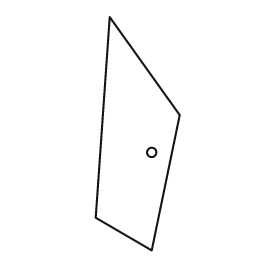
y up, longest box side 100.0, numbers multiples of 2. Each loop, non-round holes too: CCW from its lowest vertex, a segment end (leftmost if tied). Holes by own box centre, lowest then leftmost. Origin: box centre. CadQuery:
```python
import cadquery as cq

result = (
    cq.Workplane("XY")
    .moveTo(6.0, -50.0)
    .lineTo(18.0, 8.0)
    .lineTo(-12.0, 50.0)
    .lineTo(-18.0, -36.0)
    .close()
    .moveTo(6.0, -8.0)
    .circle(2.0)
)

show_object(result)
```